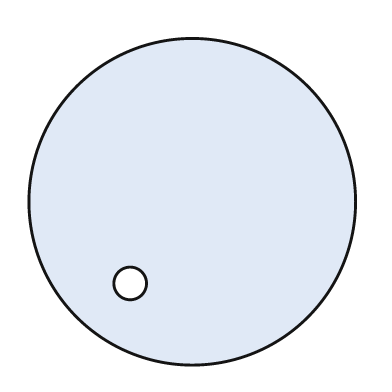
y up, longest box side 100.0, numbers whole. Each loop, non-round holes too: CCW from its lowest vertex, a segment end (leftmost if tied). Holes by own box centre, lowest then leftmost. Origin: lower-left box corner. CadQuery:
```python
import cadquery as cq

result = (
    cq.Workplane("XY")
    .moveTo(50.0, 50.0)
    .circle(50.0)
    .moveTo(31.0, 25.0)
    .circle(5.0)
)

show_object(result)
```